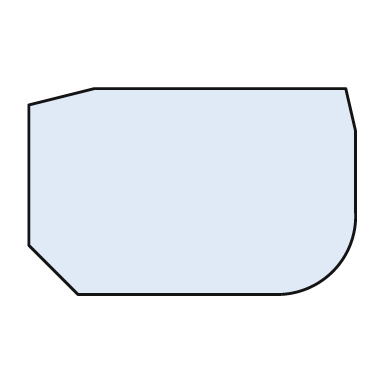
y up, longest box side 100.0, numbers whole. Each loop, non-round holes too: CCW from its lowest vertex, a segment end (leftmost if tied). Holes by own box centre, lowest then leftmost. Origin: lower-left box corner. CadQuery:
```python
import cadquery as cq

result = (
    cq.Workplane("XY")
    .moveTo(15.0, 0.0)
    .lineTo(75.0, 0.0)
    .threePointArc((93.0, 7.0), (100.0, 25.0))
    .lineTo(100.0, 50.0)
    .lineTo(97.0, 63.0)
    .lineTo(20.0, 63.0)
    .lineTo(0.0, 58.0)
    .lineTo(0.0, 15.0)
    .close()
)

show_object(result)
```